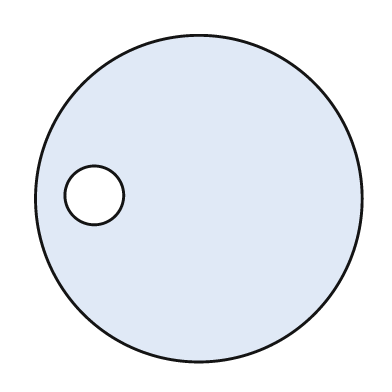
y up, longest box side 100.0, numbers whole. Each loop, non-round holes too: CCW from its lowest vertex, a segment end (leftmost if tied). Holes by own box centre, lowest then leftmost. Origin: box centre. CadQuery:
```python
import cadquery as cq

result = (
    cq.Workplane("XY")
    .moveTo(0.0, 0.0)
    .circle(50.0)
    .moveTo(-32.0, 1.0)
    .circle(9.0)
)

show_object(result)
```